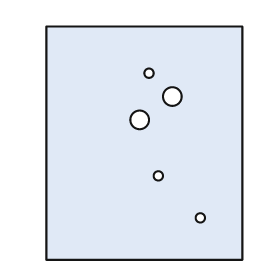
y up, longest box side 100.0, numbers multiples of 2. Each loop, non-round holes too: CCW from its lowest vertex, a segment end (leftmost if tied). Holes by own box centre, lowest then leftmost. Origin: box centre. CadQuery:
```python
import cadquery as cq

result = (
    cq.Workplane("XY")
    .moveTo(-42.0, -50.0)
    .lineTo(42.0, -50.0)
    .lineTo(42.0, 50.0)
    .lineTo(-42.0, 50.0)
    .close()
    .moveTo(24.0, -32.0)
    .circle(2.0)
    .moveTo(6.0, -14.0)
    .circle(2.0)
    .moveTo(-2.0, 10.0)
    .circle(4.0)
    .moveTo(12.0, 20.0)
    .circle(4.0)
    .moveTo(2.0, 30.0)
    .circle(2.0)
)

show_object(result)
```